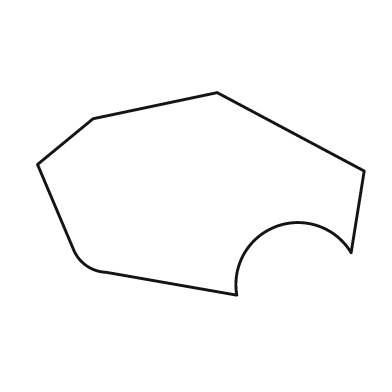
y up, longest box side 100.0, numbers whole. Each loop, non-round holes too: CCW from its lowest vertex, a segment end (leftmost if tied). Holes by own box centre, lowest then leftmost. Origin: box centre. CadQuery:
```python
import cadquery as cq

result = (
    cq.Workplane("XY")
    .moveTo(11.0, -31.0)
    .threePointArc((23.0, -10.0), (46.0, -18.0))
    .lineTo(50.0, 7.0)
    .lineTo(5.0, 31.0)
    .lineTo(-33.0, 23.0)
    .lineTo(-50.0, 9.0)
    .lineTo(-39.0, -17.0)
    .threePointArc((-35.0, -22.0), (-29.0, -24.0))
    .close()
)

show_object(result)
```